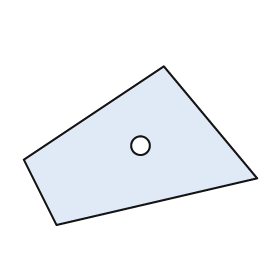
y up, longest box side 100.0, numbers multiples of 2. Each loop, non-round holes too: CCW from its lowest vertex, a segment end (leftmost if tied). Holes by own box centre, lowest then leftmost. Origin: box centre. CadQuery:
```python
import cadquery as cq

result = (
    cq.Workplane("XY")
    .moveTo(-36.0, -34.0)
    .lineTo(50.0, -14.0)
    .lineTo(10.0, 34.0)
    .lineTo(-50.0, -6.0)
    .close()
    .moveTo(0.0, 0.0)
    .circle(4.0)
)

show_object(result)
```